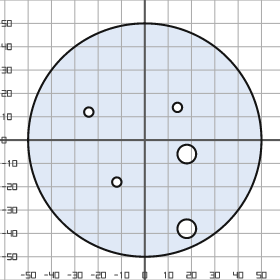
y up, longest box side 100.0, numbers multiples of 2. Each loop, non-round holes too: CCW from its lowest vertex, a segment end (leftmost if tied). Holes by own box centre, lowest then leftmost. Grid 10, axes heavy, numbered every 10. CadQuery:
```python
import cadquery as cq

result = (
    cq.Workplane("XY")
    .moveTo(0.0, 0.0)
    .circle(50.0)
    .moveTo(18.0, -38.0)
    .circle(4.0)
    .moveTo(-12.0, -18.0)
    .circle(2.0)
    .moveTo(18.0, -6.0)
    .circle(4.0)
    .moveTo(-24.0, 12.0)
    .circle(2.0)
    .moveTo(14.0, 14.0)
    .circle(2.0)
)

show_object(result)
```